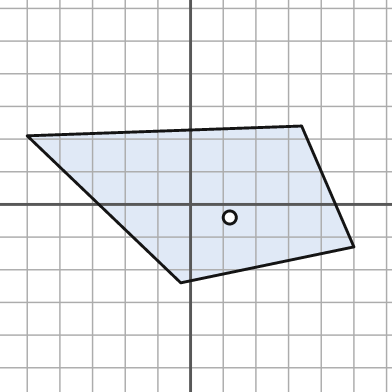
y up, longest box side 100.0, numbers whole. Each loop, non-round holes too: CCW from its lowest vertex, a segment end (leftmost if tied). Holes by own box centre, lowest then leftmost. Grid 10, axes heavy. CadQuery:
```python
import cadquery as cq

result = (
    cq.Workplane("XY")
    .moveTo(-3.0, -24.0)
    .lineTo(50.0, -13.0)
    .lineTo(34.0, 24.0)
    .lineTo(-50.0, 21.0)
    .close()
    .moveTo(12.0, -4.0)
    .circle(2.0)
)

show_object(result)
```